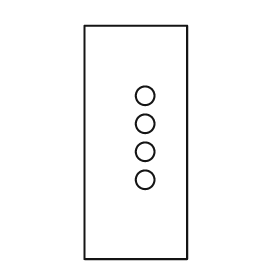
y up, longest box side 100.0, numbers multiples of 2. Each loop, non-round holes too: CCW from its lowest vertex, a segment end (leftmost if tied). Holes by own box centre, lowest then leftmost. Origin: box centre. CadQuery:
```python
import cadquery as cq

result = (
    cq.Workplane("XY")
    .moveTo(-22.0, -50.0)
    .lineTo(22.0, -50.0)
    .lineTo(22.0, 50.0)
    .lineTo(-22.0, 50.0)
    .close()
    .moveTo(4.0, -16.0)
    .circle(4.0)
    .moveTo(4.0, -4.0)
    .circle(4.0)
    .moveTo(4.0, 8.0)
    .circle(4.0)
    .moveTo(4.0, 20.0)
    .circle(4.0)
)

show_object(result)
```